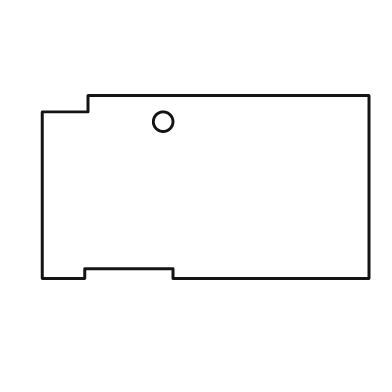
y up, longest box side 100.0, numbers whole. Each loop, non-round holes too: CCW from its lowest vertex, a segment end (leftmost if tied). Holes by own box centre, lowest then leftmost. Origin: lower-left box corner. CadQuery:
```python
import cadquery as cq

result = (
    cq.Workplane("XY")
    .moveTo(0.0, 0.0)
    .lineTo(13.0, 0.0)
    .lineTo(13.0, 3.0)
    .lineTo(40.0, 3.0)
    .lineTo(40.0, 0.0)
    .lineTo(100.0, 0.0)
    .lineTo(100.0, 56.0)
    .lineTo(14.0, 56.0)
    .lineTo(14.0, 51.0)
    .lineTo(0.0, 51.0)
    .close()
    .moveTo(37.0, 48.0)
    .circle(3.0)
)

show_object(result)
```